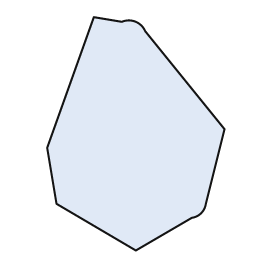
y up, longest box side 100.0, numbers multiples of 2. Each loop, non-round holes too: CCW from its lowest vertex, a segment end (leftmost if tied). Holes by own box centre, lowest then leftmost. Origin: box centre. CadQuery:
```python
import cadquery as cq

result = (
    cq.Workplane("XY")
    .moveTo(0.0, -50.0)
    .lineTo(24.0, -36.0)
    .threePointArc((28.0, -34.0), (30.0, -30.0))
    .lineTo(38.0, 2.0)
    .lineTo(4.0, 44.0)
    .threePointArc((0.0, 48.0), (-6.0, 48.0))
    .lineTo(-18.0, 50.0)
    .lineTo(-38.0, -6.0)
    .lineTo(-34.0, -30.0)
    .close()
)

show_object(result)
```